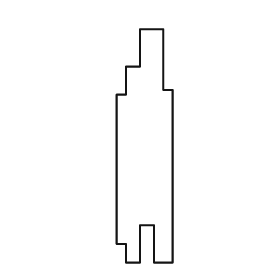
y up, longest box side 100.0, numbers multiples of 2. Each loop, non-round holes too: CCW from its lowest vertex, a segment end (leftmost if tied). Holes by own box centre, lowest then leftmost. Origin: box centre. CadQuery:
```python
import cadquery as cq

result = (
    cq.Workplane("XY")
    .moveTo(-8.0, -50.0)
    .lineTo(-2.0, -50.0)
    .lineTo(-2.0, -34.0)
    .lineTo(4.0, -34.0)
    .lineTo(4.0, -50.0)
    .lineTo(12.0, -50.0)
    .lineTo(12.0, 24.0)
    .lineTo(8.0, 24.0)
    .lineTo(8.0, 50.0)
    .lineTo(-2.0, 50.0)
    .lineTo(-2.0, 34.0)
    .lineTo(-8.0, 34.0)
    .lineTo(-8.0, 22.0)
    .lineTo(-12.0, 22.0)
    .lineTo(-12.0, -42.0)
    .lineTo(-8.0, -42.0)
    .close()
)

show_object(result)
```